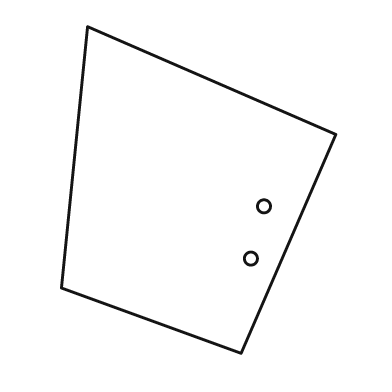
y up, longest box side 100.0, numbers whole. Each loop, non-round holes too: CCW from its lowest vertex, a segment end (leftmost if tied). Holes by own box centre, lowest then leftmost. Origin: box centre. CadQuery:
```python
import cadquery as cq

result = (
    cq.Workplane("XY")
    .moveTo(13.0, -50.0)
    .lineTo(42.0, 17.0)
    .lineTo(-34.0, 50.0)
    .lineTo(-42.0, -30.0)
    .close()
    .moveTo(16.0, -21.0)
    .circle(2.0)
    .moveTo(20.0, -5.0)
    .circle(2.0)
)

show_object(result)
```